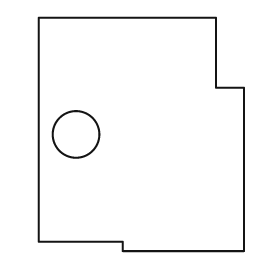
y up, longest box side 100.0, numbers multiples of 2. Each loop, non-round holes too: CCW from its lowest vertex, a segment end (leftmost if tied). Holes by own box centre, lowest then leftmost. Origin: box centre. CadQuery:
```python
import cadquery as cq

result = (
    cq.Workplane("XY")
    .moveTo(-8.0, -50.0)
    .lineTo(44.0, -50.0)
    .lineTo(44.0, 20.0)
    .lineTo(32.0, 20.0)
    .lineTo(32.0, 50.0)
    .lineTo(-44.0, 50.0)
    .lineTo(-44.0, -46.0)
    .lineTo(-8.0, -46.0)
    .close()
    .moveTo(-28.0, 0.0)
    .circle(10.0)
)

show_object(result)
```